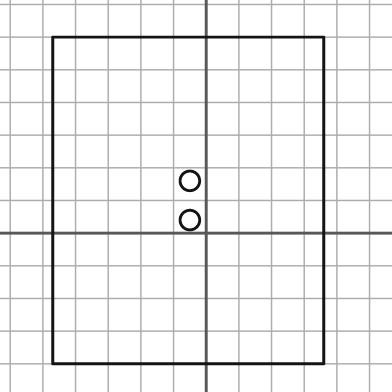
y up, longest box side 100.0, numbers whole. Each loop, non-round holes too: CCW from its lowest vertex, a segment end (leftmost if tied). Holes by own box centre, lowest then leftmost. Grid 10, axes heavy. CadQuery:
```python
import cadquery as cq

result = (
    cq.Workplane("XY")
    .moveTo(-47.0, -40.0)
    .lineTo(36.0, -40.0)
    .lineTo(36.0, 60.0)
    .lineTo(-47.0, 60.0)
    .close()
    .moveTo(-5.0, 4.0)
    .circle(3.0)
    .moveTo(-5.0, 16.0)
    .circle(3.0)
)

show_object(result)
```